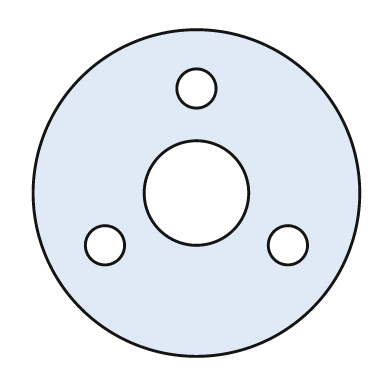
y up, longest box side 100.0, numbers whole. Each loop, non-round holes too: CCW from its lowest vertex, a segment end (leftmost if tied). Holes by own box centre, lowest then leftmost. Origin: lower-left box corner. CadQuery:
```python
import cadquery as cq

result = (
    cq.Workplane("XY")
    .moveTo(50.0, 50.0)
    .circle(50.0)
    .moveTo(22.0, 34.0)
    .circle(6.0)
    .moveTo(78.0, 34.0)
    .circle(6.0)
    .moveTo(50.0, 50.0)
    .circle(16.0)
    .moveTo(50.0, 82.0)
    .circle(6.0)
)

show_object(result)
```